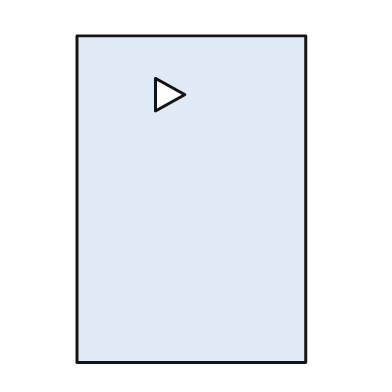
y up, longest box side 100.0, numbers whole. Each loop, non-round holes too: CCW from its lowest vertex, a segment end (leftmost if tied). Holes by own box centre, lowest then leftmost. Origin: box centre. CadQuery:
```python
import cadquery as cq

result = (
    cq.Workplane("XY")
    .moveTo(-35.0, -50.0)
    .lineTo(35.0, -50.0)
    .lineTo(35.0, 50.0)
    .lineTo(-35.0, 50.0)
    .close()
    .moveTo(-11.0, 27.0)
    .lineTo(-2.0, 32.0)
    .lineTo(-11.0, 37.0)
    .close()
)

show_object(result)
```